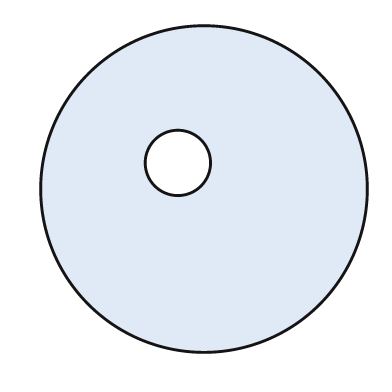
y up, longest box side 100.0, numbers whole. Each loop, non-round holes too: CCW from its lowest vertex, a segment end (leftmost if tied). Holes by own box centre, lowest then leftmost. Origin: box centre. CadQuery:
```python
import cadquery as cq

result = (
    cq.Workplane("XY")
    .moveTo(0.0, 0.0)
    .circle(50.0)
    .moveTo(-8.0, 8.0)
    .circle(10.0)
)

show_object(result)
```